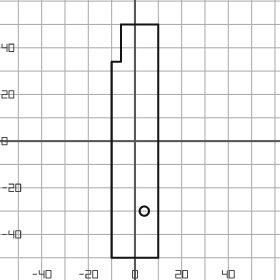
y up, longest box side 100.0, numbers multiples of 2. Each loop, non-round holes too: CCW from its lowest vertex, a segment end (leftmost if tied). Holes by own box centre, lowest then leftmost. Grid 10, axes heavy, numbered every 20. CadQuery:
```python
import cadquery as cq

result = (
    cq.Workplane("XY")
    .moveTo(-10.0, -50.0)
    .lineTo(10.0, -50.0)
    .lineTo(10.0, 50.0)
    .lineTo(-6.0, 50.0)
    .lineTo(-6.0, 34.0)
    .lineTo(-10.0, 34.0)
    .close()
    .moveTo(4.0, -30.0)
    .circle(2.0)
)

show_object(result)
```